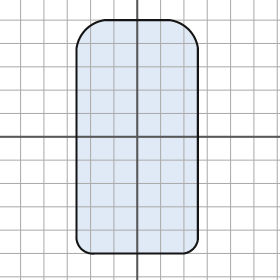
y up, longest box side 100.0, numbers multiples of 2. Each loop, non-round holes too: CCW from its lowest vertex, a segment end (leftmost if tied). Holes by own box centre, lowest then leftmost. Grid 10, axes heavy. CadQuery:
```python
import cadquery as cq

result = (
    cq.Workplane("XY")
    .moveTo(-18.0, -50.0)
    .lineTo(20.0, -50.0)
    .threePointArc((24.0, -48.0), (26.0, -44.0))
    .lineTo(26.0, 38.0)
    .threePointArc((22.0, 46.0), (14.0, 50.0))
    .lineTo(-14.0, 50.0)
    .threePointArc((-22.0, 46.0), (-26.0, 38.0))
    .lineTo(-26.0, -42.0)
    .threePointArc((-24.0, -48.0), (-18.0, -50.0))
    .close()
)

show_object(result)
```